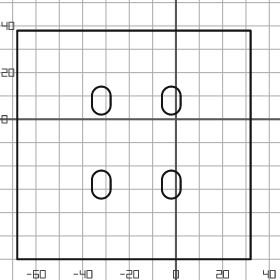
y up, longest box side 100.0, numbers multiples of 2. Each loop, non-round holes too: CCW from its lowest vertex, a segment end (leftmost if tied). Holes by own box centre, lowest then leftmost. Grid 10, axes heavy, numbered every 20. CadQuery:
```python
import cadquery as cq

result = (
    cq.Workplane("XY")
    .moveTo(-68.0, -60.0)
    .lineTo(32.0, -60.0)
    .lineTo(32.0, 38.0)
    .lineTo(-68.0, 38.0)
    .close()
    .moveTo(-36.0, -30.0)
    .threePointArc((-32.0, -34.0), (-28.0, -30.0))
    .lineTo(-28.0, -26.0)
    .threePointArc((-32.0, -22.0), (-36.0, -26.0))
    .close()
    .moveTo(-6.0, -30.0)
    .threePointArc((-2.0, -34.0), (2.0, -30.0))
    .lineTo(2.0, -26.0)
    .threePointArc((-2.0, -22.0), (-6.0, -26.0))
    .close()
    .moveTo(-36.0, 6.0)
    .threePointArc((-32.0, 2.0), (-28.0, 6.0))
    .lineTo(-28.0, 10.0)
    .threePointArc((-32.0, 14.0), (-36.0, 10.0))
    .close()
    .moveTo(-6.0, 6.0)
    .threePointArc((-2.0, 2.0), (2.0, 6.0))
    .lineTo(2.0, 10.0)
    .threePointArc((-2.0, 14.0), (-6.0, 10.0))
    .close()
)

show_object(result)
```